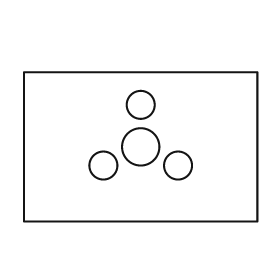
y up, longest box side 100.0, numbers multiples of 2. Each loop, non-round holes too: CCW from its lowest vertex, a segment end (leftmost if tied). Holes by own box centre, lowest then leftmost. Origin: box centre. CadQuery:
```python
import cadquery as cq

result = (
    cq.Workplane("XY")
    .moveTo(-50.0, -32.0)
    .lineTo(50.0, -32.0)
    .lineTo(50.0, 32.0)
    .lineTo(-50.0, 32.0)
    .close()
    .moveTo(-16.0, -8.0)
    .circle(6.0)
    .moveTo(16.0, -8.0)
    .circle(6.0)
    .moveTo(0.0, 0.0)
    .circle(8.0)
    .moveTo(0.0, 18.0)
    .circle(6.0)
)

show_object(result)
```